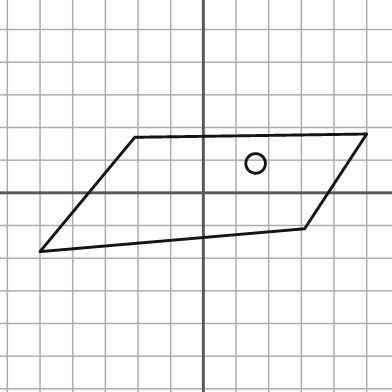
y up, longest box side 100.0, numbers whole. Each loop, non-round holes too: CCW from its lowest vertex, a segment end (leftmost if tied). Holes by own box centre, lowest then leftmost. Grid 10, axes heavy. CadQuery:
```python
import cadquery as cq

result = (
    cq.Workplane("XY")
    .moveTo(-50.0, -18.0)
    .lineTo(31.0, -11.0)
    .lineTo(50.0, 18.0)
    .lineTo(-21.0, 17.0)
    .close()
    .moveTo(16.0, 9.0)
    .circle(3.0)
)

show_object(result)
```